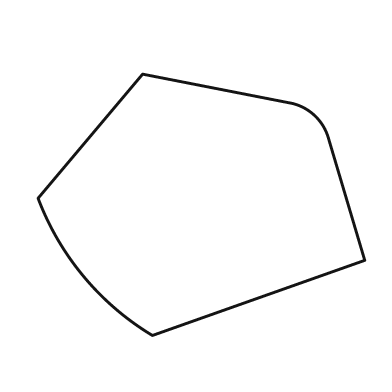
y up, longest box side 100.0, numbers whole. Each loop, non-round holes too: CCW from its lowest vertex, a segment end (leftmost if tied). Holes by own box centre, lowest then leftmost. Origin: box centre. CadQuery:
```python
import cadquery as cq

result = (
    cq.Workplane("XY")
    .moveTo(-15.0, -40.0)
    .lineTo(50.0, -17.0)
    .lineTo(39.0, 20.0)
    .threePointArc((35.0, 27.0), (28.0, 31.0))
    .lineTo(-18.0, 40.0)
    .lineTo(-50.0, 2.0)
    .threePointArc((-36.0, -22.0), (-15.0, -40.0))
    .close()
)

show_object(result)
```